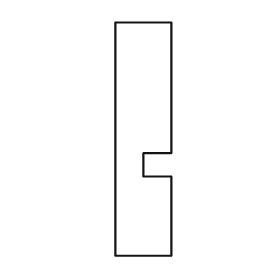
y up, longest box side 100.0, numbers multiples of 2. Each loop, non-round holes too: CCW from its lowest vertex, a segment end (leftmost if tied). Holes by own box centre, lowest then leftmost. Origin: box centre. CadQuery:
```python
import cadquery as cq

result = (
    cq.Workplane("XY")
    .moveTo(-12.0, -50.0)
    .lineTo(12.0, -50.0)
    .lineTo(12.0, -16.0)
    .lineTo(0.0, -16.0)
    .lineTo(0.0, -6.0)
    .lineTo(12.0, -6.0)
    .lineTo(12.0, 50.0)
    .lineTo(-12.0, 50.0)
    .close()
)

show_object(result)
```